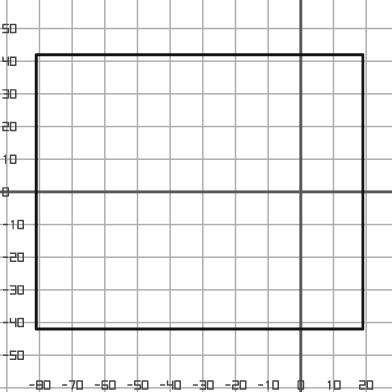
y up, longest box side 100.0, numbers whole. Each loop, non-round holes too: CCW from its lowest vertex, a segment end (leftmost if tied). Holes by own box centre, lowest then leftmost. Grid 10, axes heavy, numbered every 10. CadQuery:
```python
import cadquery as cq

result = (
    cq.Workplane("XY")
    .moveTo(-81.0, -42.0)
    .lineTo(19.0, -42.0)
    .lineTo(19.0, 42.0)
    .lineTo(-81.0, 42.0)
    .close()
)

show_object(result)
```